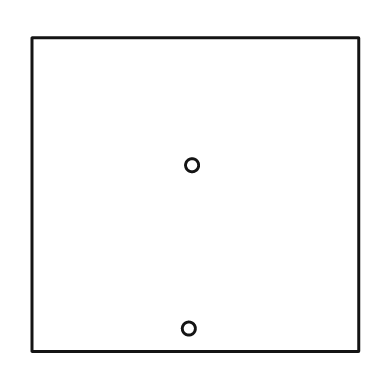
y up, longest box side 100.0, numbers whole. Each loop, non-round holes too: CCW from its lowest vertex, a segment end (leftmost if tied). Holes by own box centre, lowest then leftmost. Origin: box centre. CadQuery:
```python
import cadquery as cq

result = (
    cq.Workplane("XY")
    .moveTo(-50.0, -48.0)
    .lineTo(50.0, -48.0)
    .lineTo(50.0, 48.0)
    .lineTo(-50.0, 48.0)
    .close()
    .moveTo(-2.0, -41.0)
    .circle(2.0)
    .moveTo(-1.0, 9.0)
    .circle(2.0)
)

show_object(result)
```